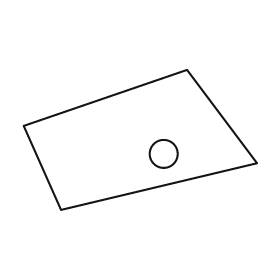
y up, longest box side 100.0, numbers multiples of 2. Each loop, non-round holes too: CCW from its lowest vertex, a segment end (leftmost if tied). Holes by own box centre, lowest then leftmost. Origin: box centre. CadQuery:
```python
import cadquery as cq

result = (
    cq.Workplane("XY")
    .moveTo(-34.0, -30.0)
    .lineTo(50.0, -10.0)
    .lineTo(20.0, 30.0)
    .lineTo(-50.0, 6.0)
    .close()
    .moveTo(10.0, -6.0)
    .circle(6.0)
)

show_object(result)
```